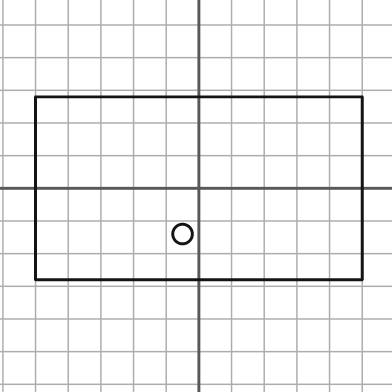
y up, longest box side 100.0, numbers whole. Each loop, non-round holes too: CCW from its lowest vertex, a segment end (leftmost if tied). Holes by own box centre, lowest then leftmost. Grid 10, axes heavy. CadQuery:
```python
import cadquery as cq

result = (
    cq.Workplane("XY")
    .moveTo(-50.0, -28.0)
    .lineTo(50.0, -28.0)
    .lineTo(50.0, 28.0)
    .lineTo(-50.0, 28.0)
    .close()
    .moveTo(-5.0, -14.0)
    .circle(3.0)
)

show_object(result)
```